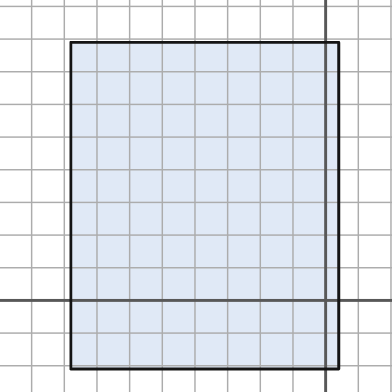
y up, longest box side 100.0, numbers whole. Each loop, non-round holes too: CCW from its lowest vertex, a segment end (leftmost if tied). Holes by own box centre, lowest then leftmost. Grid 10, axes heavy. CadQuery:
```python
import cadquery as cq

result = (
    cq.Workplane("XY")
    .moveTo(-78.0, -21.0)
    .lineTo(4.0, -21.0)
    .lineTo(4.0, 79.0)
    .lineTo(-78.0, 79.0)
    .close()
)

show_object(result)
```